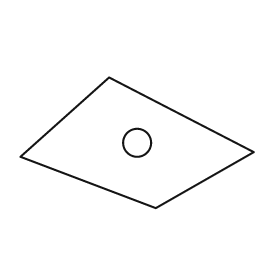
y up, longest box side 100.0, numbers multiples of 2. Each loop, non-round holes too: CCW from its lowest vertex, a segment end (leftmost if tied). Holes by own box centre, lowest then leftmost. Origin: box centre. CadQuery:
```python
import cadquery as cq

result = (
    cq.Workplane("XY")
    .moveTo(8.0, -28.0)
    .lineTo(50.0, -4.0)
    .lineTo(-12.0, 28.0)
    .lineTo(-50.0, -6.0)
    .close()
    .moveTo(0.0, 0.0)
    .circle(6.0)
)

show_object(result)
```